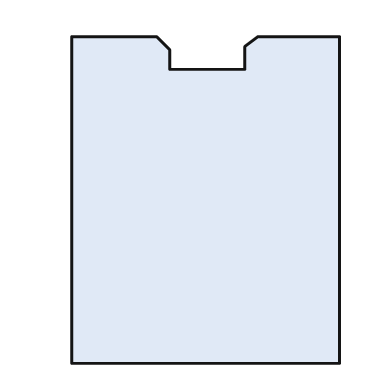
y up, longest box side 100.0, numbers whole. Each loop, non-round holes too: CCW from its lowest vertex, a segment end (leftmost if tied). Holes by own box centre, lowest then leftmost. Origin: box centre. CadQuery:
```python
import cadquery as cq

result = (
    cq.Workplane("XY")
    .moveTo(-41.0, -50.0)
    .lineTo(41.0, -50.0)
    .lineTo(41.0, 50.0)
    .lineTo(16.0, 50.0)
    .lineTo(12.0, 47.0)
    .lineTo(12.0, 40.0)
    .lineTo(-11.0, 40.0)
    .lineTo(-11.0, 46.0)
    .lineTo(-15.0, 50.0)
    .lineTo(-41.0, 50.0)
    .close()
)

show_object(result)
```